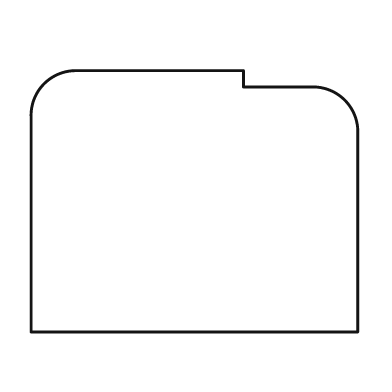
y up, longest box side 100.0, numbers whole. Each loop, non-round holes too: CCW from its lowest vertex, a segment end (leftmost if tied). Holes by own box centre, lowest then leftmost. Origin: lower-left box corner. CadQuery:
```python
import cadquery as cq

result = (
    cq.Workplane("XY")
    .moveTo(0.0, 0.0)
    .lineTo(100.0, 0.0)
    .lineTo(100.0, 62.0)
    .threePointArc((96.0, 71.0), (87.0, 75.0))
    .lineTo(65.0, 75.0)
    .lineTo(65.0, 80.0)
    .lineTo(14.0, 80.0)
    .threePointArc((4.0, 76.0), (0.0, 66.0))
    .close()
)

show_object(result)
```